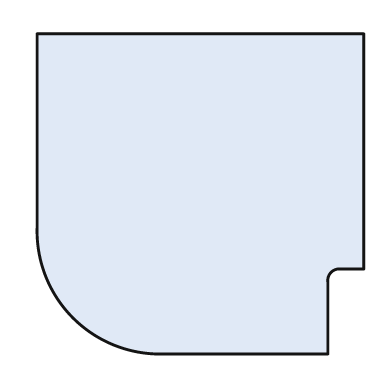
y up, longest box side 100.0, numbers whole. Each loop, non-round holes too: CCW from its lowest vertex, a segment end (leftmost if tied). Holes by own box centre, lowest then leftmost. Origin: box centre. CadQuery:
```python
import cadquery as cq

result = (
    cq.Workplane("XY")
    .moveTo(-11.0, -49.0)
    .lineTo(39.0, -49.0)
    .lineTo(39.0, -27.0)
    .threePointArc((40.0, -24.0), (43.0, -23.0))
    .lineTo(50.0, -23.0)
    .lineTo(50.0, 49.0)
    .lineTo(-50.0, 49.0)
    .lineTo(-50.0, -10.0)
    .threePointArc((-39.0, -38.0), (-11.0, -49.0))
    .close()
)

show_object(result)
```